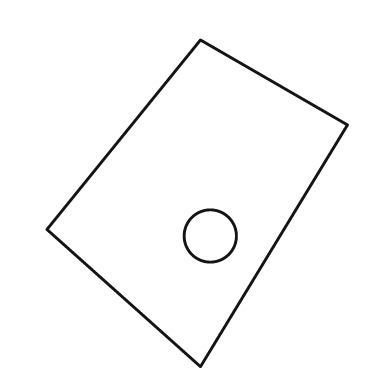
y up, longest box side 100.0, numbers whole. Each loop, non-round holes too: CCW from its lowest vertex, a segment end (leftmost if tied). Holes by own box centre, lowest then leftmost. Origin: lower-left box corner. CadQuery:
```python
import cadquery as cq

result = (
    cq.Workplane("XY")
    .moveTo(47.0, 0.0)
    .lineTo(92.0, 74.0)
    .lineTo(47.0, 100.0)
    .lineTo(0.0, 42.0)
    .close()
    .moveTo(50.0, 40.0)
    .circle(8.0)
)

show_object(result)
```